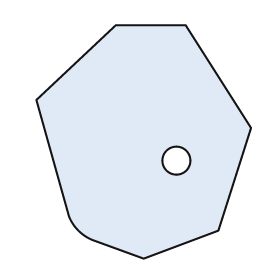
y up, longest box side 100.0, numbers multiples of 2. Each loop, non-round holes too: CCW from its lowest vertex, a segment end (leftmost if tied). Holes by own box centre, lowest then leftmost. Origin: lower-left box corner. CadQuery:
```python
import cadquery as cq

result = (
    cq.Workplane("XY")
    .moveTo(46.0, 0.0)
    .lineTo(78.0, 12.0)
    .lineTo(92.0, 56.0)
    .lineTo(64.0, 100.0)
    .lineTo(34.0, 100.0)
    .lineTo(0.0, 68.0)
    .lineTo(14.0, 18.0)
    .threePointArc((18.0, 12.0), (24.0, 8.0))
    .close()
    .moveTo(60.0, 42.0)
    .circle(6.0)
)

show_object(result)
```